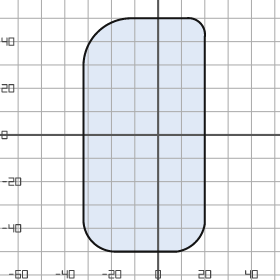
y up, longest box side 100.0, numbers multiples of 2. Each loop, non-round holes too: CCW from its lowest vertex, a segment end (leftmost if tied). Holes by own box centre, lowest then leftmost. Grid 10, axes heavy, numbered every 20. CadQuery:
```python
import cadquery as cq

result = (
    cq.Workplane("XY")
    .moveTo(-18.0, -50.0)
    .lineTo(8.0, -50.0)
    .threePointArc((16.0, -46.0), (20.0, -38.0))
    .lineTo(20.0, 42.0)
    .threePointArc((18.0, 48.0), (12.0, 50.0))
    .lineTo(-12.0, 50.0)
    .threePointArc((-26.0, 44.0), (-32.0, 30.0))
    .lineTo(-32.0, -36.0)
    .threePointArc((-28.0, -46.0), (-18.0, -50.0))
    .close()
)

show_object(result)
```